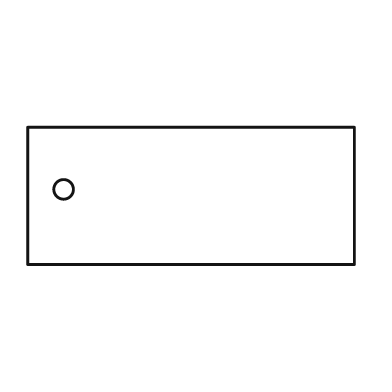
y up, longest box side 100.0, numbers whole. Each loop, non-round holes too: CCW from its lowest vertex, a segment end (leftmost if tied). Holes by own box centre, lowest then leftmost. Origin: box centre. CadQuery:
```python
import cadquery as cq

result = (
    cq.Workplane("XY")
    .moveTo(-50.0, -21.0)
    .lineTo(50.0, -21.0)
    .lineTo(50.0, 21.0)
    .lineTo(-50.0, 21.0)
    .close()
    .moveTo(-39.0, 2.0)
    .circle(3.0)
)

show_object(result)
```